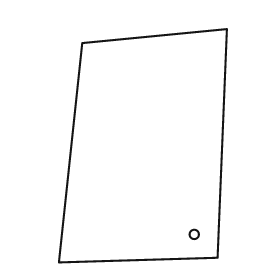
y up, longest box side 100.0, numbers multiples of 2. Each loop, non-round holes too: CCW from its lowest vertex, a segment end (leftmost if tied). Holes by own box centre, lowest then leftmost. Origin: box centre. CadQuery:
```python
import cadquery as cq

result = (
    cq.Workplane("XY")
    .moveTo(-36.0, -50.0)
    .lineTo(32.0, -48.0)
    .lineTo(36.0, 50.0)
    .lineTo(-26.0, 44.0)
    .close()
    .moveTo(22.0, -38.0)
    .circle(2.0)
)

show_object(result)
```